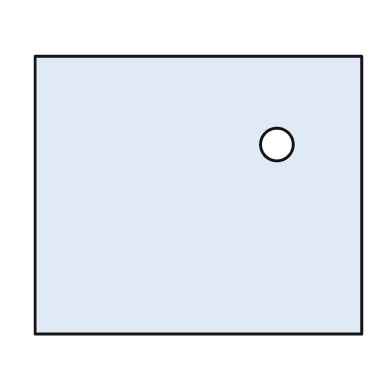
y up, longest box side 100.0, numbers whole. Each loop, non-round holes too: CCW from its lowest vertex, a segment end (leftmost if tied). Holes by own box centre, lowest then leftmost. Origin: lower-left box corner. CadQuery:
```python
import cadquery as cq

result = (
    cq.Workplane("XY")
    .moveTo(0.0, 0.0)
    .lineTo(100.0, 0.0)
    .lineTo(100.0, 85.0)
    .lineTo(0.0, 85.0)
    .close()
    .moveTo(74.0, 58.0)
    .circle(5.0)
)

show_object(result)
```